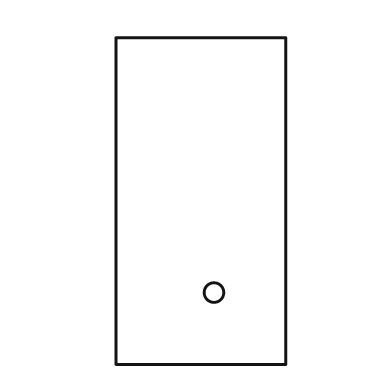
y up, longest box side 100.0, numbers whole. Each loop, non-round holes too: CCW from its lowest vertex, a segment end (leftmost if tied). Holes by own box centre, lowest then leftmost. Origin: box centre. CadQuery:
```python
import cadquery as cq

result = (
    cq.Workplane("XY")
    .moveTo(-26.0, -50.0)
    .lineTo(26.0, -50.0)
    .lineTo(26.0, 50.0)
    .lineTo(-26.0, 50.0)
    .close()
    .moveTo(4.0, -28.0)
    .circle(3.0)
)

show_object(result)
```